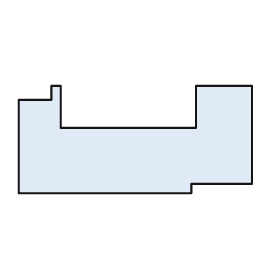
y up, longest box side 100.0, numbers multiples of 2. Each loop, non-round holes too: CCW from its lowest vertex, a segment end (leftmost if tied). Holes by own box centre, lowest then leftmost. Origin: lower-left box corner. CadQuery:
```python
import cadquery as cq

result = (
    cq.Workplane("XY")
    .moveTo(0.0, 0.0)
    .lineTo(74.0, 0.0)
    .lineTo(74.0, 4.0)
    .lineTo(100.0, 4.0)
    .lineTo(100.0, 46.0)
    .lineTo(76.0, 46.0)
    .lineTo(76.0, 28.0)
    .lineTo(18.0, 28.0)
    .lineTo(18.0, 46.0)
    .lineTo(14.0, 46.0)
    .lineTo(14.0, 40.0)
    .lineTo(0.0, 40.0)
    .close()
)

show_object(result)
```